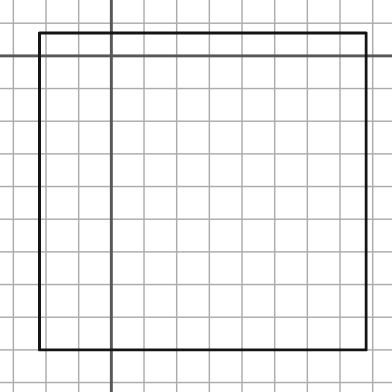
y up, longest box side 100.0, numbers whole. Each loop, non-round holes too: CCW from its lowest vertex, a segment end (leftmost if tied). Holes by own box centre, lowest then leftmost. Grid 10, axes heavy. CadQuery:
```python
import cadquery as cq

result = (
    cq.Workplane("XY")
    .moveTo(-22.0, -90.0)
    .lineTo(78.0, -90.0)
    .lineTo(78.0, 7.0)
    .lineTo(-22.0, 7.0)
    .close()
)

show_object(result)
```